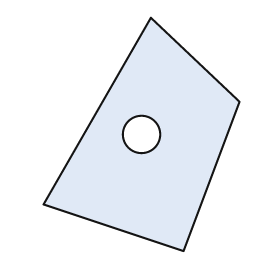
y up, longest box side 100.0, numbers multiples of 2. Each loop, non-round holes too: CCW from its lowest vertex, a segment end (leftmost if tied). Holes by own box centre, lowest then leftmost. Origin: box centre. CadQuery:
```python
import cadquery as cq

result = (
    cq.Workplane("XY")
    .moveTo(18.0, -50.0)
    .lineTo(42.0, 14.0)
    .lineTo(4.0, 50.0)
    .lineTo(-42.0, -30.0)
    .close()
    .moveTo(0.0, 0.0)
    .circle(8.0)
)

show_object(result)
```